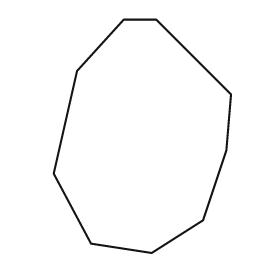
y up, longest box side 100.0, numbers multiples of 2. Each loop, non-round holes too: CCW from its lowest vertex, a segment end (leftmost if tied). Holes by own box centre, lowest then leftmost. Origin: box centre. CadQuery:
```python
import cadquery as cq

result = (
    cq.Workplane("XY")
    .moveTo(4.0, -50.0)
    .lineTo(26.0, -36.0)
    .lineTo(36.0, -6.0)
    .lineTo(38.0, 18.0)
    .lineTo(6.0, 50.0)
    .lineTo(-8.0, 50.0)
    .lineTo(-28.0, 28.0)
    .lineTo(-38.0, -16.0)
    .lineTo(-22.0, -46.0)
    .close()
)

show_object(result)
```